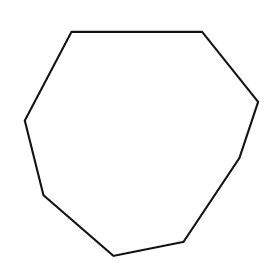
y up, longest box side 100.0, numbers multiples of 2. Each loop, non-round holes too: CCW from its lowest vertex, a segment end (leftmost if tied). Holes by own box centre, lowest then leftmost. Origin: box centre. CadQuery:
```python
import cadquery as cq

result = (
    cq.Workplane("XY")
    .moveTo(-12.0, -48.0)
    .lineTo(18.0, -42.0)
    .lineTo(42.0, -6.0)
    .lineTo(50.0, 18.0)
    .lineTo(26.0, 48.0)
    .lineTo(-30.0, 48.0)
    .lineTo(-50.0, 10.0)
    .lineTo(-42.0, -22.0)
    .close()
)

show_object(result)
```